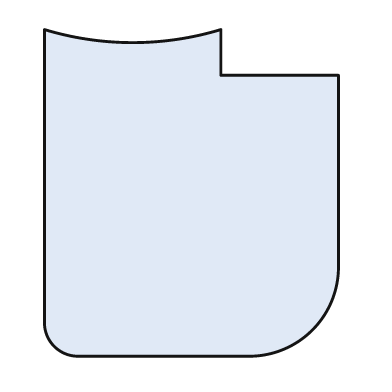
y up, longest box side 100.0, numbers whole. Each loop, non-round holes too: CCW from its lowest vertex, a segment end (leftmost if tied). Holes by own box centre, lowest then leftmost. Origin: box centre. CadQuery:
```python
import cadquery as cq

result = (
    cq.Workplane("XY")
    .moveTo(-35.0, -50.0)
    .lineTo(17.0, -50.0)
    .threePointArc((37.0, -42.0), (45.0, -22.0))
    .lineTo(45.0, 36.0)
    .lineTo(9.0, 36.0)
    .lineTo(9.0, 50.0)
    .threePointArc((-18.0, 46.0), (-45.0, 50.0))
    .lineTo(-45.0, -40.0)
    .threePointArc((-42.0, -47.0), (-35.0, -50.0))
    .close()
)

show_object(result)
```